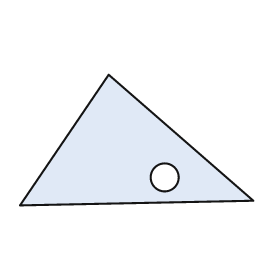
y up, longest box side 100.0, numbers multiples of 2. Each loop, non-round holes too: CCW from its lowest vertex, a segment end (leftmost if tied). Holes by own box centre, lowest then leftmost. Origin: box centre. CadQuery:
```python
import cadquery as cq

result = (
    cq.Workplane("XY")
    .moveTo(-50.0, -28.0)
    .lineTo(50.0, -26.0)
    .lineTo(-12.0, 28.0)
    .close()
    .moveTo(12.0, -16.0)
    .circle(6.0)
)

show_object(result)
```